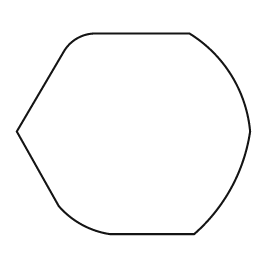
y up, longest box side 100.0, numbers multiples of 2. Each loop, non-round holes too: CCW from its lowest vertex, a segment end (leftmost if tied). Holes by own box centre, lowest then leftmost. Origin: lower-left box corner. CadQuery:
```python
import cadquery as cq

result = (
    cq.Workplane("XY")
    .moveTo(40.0, 0.0)
    .lineTo(76.0, 0.0)
    .threePointArc((92.0, 20.0), (100.0, 44.0))
    .threePointArc((92.0, 68.0), (74.0, 86.0))
    .lineTo(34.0, 86.0)
    .threePointArc((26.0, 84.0), (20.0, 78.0))
    .lineTo(0.0, 44.0)
    .lineTo(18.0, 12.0)
    .threePointArc((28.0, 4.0), (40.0, 0.0))
    .close()
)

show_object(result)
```